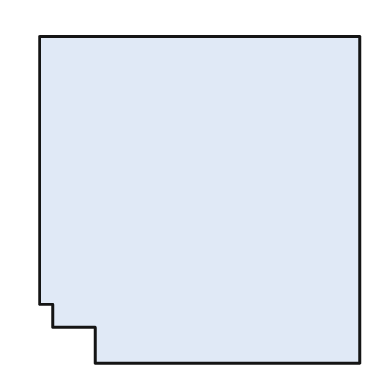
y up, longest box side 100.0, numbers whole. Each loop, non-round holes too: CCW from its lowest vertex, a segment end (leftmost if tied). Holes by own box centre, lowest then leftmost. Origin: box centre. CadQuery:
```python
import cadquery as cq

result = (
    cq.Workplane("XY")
    .moveTo(-32.0, -50.0)
    .lineTo(49.0, -50.0)
    .lineTo(49.0, 50.0)
    .lineTo(-49.0, 50.0)
    .lineTo(-49.0, -32.0)
    .lineTo(-45.0, -32.0)
    .lineTo(-45.0, -39.0)
    .lineTo(-32.0, -39.0)
    .close()
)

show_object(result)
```